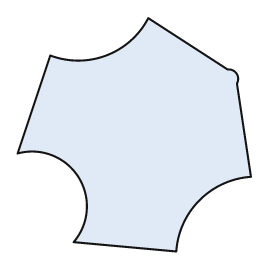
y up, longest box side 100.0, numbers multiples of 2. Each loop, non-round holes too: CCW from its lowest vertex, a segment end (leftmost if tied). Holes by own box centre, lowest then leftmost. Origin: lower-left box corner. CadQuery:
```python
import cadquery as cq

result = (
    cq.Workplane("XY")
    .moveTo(68.0, 0.0)
    .threePointArc((78.0, 22.0), (100.0, 32.0))
    .lineTo(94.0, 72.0)
    .threePointArc((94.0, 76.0), (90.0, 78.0))
    .lineTo(56.0, 100.0)
    .threePointArc((38.0, 84.0), (14.0, 84.0))
    .lineTo(0.0, 42.0)
    .threePointArc((26.0, 32.0), (24.0, 4.0))
    .close()
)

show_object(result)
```